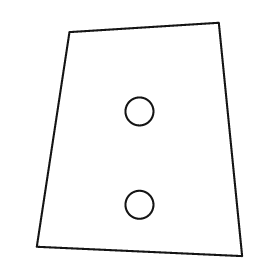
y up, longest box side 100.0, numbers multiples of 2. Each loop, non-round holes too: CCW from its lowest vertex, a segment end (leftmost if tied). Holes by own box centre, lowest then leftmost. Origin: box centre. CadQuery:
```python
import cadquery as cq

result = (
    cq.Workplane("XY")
    .moveTo(44.0, -50.0)
    .lineTo(34.0, 50.0)
    .lineTo(-30.0, 46.0)
    .lineTo(-44.0, -46.0)
    .close()
    .moveTo(0.0, -28.0)
    .circle(6.0)
    .moveTo(0.0, 12.0)
    .circle(6.0)
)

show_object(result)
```